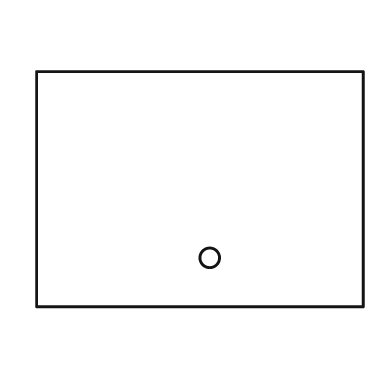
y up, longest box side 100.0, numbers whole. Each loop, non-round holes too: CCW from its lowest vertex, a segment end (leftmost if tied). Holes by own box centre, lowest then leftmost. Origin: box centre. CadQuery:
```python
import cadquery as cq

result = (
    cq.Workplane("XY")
    .moveTo(-50.0, -36.0)
    .lineTo(50.0, -36.0)
    .lineTo(50.0, 36.0)
    .lineTo(-50.0, 36.0)
    .close()
    .moveTo(3.0, -21.0)
    .circle(3.0)
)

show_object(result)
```